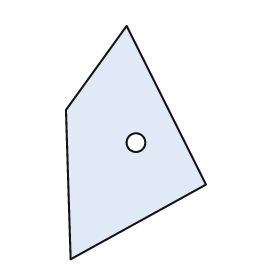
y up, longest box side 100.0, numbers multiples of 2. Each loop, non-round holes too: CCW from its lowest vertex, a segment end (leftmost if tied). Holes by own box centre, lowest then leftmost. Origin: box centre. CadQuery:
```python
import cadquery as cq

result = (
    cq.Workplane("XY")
    .moveTo(-28.0, -50.0)
    .lineTo(30.0, -18.0)
    .lineTo(-4.0, 50.0)
    .lineTo(-30.0, 14.0)
    .close()
    .moveTo(0.0, 0.0)
    .circle(4.0)
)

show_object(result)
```